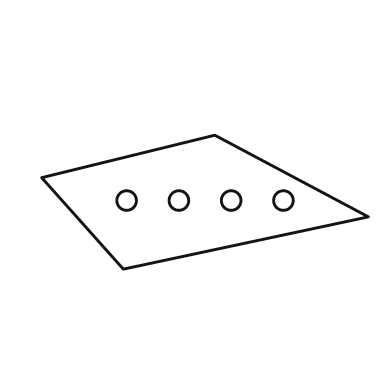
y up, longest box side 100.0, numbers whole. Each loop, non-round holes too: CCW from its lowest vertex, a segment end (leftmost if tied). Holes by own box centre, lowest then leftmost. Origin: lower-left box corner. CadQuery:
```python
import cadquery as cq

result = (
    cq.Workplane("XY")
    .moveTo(25.0, 0.0)
    .lineTo(100.0, 16.0)
    .lineTo(53.0, 41.0)
    .lineTo(0.0, 28.0)
    .close()
    .moveTo(26.0, 21.0)
    .circle(3.0)
    .moveTo(42.0, 21.0)
    .circle(3.0)
    .moveTo(58.0, 21.0)
    .circle(3.0)
    .moveTo(74.0, 21.0)
    .circle(3.0)
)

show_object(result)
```